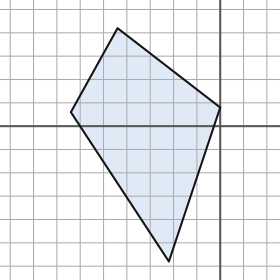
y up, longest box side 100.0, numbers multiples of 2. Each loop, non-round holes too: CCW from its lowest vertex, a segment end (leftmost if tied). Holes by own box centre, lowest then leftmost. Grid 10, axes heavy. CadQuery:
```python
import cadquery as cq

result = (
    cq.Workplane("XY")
    .moveTo(-22.0, -58.0)
    .lineTo(0.0, 8.0)
    .lineTo(-44.0, 42.0)
    .lineTo(-64.0, 6.0)
    .close()
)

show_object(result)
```